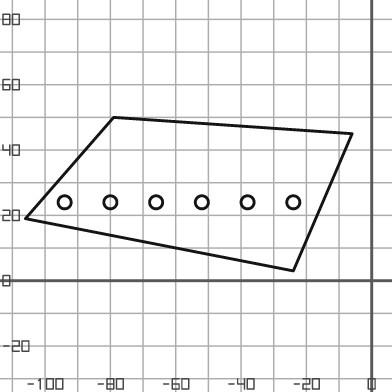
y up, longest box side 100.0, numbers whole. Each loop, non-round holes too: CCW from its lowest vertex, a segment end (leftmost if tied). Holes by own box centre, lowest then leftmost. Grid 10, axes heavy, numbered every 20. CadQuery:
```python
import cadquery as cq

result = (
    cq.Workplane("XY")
    .moveTo(-24.0, 3.0)
    .lineTo(-6.0, 45.0)
    .lineTo(-79.0, 50.0)
    .lineTo(-106.0, 19.0)
    .close()
    .moveTo(-94.0, 24.0)
    .circle(2.0)
    .moveTo(-80.0, 24.0)
    .circle(2.0)
    .moveTo(-66.0, 24.0)
    .circle(2.0)
    .moveTo(-52.0, 24.0)
    .circle(2.0)
    .moveTo(-38.0, 24.0)
    .circle(2.0)
    .moveTo(-24.0, 24.0)
    .circle(2.0)
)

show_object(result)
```